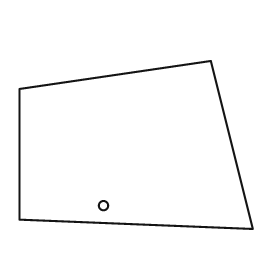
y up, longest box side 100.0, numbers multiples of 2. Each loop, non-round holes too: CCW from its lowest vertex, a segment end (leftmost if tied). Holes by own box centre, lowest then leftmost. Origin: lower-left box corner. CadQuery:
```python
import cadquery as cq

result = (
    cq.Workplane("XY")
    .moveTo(100.0, 0.0)
    .lineTo(82.0, 72.0)
    .lineTo(0.0, 60.0)
    .lineTo(0.0, 4.0)
    .close()
    .moveTo(36.0, 10.0)
    .circle(2.0)
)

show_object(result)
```